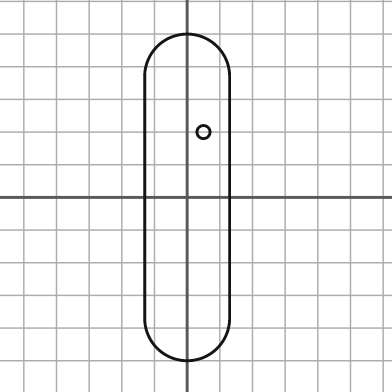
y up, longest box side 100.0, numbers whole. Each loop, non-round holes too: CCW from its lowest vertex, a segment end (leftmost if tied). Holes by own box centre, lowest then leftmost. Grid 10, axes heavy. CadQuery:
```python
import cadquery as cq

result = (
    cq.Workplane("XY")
    .moveTo(-13.0, -37.0)
    .threePointArc((0.0, -50.0), (13.0, -37.0))
    .lineTo(13.0, 37.0)
    .threePointArc((0.0, 50.0), (-13.0, 37.0))
    .close()
    .moveTo(5.0, 20.0)
    .circle(2.0)
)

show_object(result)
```